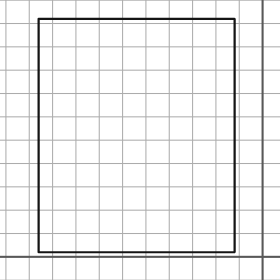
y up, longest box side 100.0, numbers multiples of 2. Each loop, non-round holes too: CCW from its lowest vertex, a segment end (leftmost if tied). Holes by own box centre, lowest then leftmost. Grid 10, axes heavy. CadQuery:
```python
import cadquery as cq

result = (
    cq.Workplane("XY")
    .moveTo(-96.0, 2.0)
    .lineTo(-12.0, 2.0)
    .lineTo(-12.0, 102.0)
    .lineTo(-96.0, 102.0)
    .close()
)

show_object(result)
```